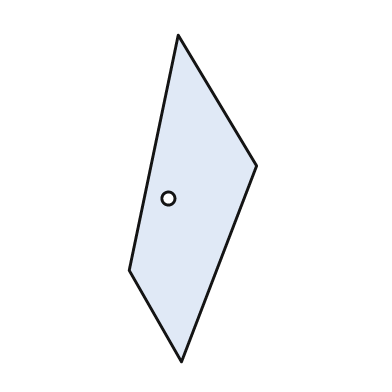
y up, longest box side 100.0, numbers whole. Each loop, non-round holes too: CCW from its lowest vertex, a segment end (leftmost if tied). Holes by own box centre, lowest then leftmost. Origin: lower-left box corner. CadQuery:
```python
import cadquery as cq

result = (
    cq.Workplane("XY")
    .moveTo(16.0, 0.0)
    .lineTo(39.0, 60.0)
    .lineTo(15.0, 100.0)
    .lineTo(0.0, 28.0)
    .close()
    .moveTo(12.0, 50.0)
    .circle(2.0)
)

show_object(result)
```